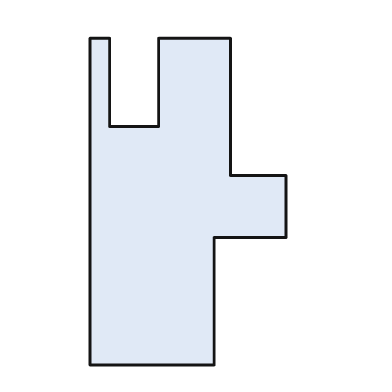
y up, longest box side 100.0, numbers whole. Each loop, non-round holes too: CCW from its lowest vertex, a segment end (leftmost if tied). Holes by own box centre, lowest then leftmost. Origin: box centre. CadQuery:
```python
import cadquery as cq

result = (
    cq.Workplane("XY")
    .moveTo(-30.0, -50.0)
    .lineTo(8.0, -50.0)
    .lineTo(8.0, -11.0)
    .lineTo(30.0, -11.0)
    .lineTo(30.0, 8.0)
    .lineTo(13.0, 8.0)
    .lineTo(13.0, 50.0)
    .lineTo(-9.0, 50.0)
    .lineTo(-9.0, 23.0)
    .lineTo(-24.0, 23.0)
    .lineTo(-24.0, 50.0)
    .lineTo(-30.0, 50.0)
    .close()
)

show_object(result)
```